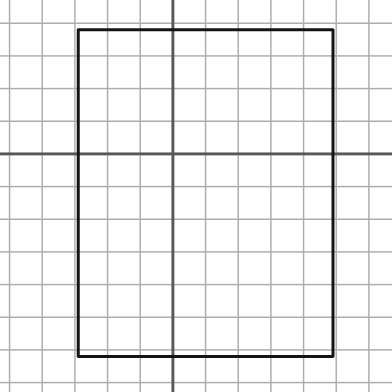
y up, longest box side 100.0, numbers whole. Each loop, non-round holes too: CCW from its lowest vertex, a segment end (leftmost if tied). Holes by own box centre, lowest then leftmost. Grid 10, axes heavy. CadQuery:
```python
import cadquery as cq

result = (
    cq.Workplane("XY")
    .moveTo(-29.0, -62.0)
    .lineTo(49.0, -62.0)
    .lineTo(49.0, 38.0)
    .lineTo(-29.0, 38.0)
    .close()
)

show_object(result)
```